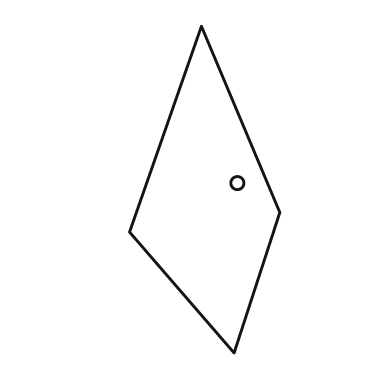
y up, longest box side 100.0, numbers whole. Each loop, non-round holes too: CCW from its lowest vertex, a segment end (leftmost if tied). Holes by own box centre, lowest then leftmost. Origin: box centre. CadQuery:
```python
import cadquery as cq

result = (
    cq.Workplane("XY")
    .moveTo(9.0, -50.0)
    .lineTo(23.0, -7.0)
    .lineTo(-1.0, 50.0)
    .lineTo(-23.0, -13.0)
    .close()
    .moveTo(10.0, 2.0)
    .circle(2.0)
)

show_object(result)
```